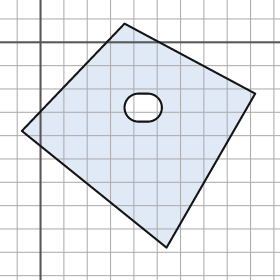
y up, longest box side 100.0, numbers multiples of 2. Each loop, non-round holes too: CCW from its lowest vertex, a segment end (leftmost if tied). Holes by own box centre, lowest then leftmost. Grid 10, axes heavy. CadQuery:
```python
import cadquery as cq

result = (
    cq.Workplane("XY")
    .moveTo(54.0, -88.0)
    .lineTo(92.0, -22.0)
    .lineTo(36.0, 8.0)
    .lineTo(-8.0, -38.0)
    .close()
    .moveTo(42.0, -34.0)
    .lineTo(46.0, -34.0)
    .threePointArc((52.0, -28.0), (46.0, -22.0))
    .lineTo(42.0, -22.0)
    .threePointArc((36.0, -28.0), (42.0, -34.0))
    .close()
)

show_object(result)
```